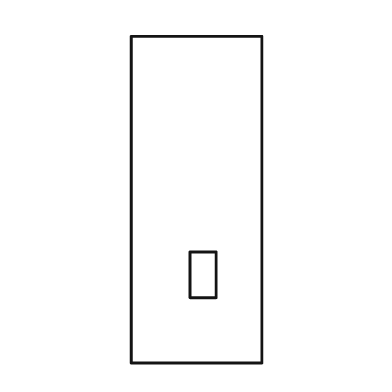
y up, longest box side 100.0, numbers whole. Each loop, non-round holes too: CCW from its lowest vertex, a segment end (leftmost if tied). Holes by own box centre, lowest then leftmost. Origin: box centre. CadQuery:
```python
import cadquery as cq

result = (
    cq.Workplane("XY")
    .moveTo(-20.0, -50.0)
    .lineTo(20.0, -50.0)
    .lineTo(20.0, 50.0)
    .lineTo(-20.0, 50.0)
    .close()
    .moveTo(-2.0, -30.0)
    .lineTo(6.0, -30.0)
    .lineTo(6.0, -16.0)
    .lineTo(-2.0, -16.0)
    .close()
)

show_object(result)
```